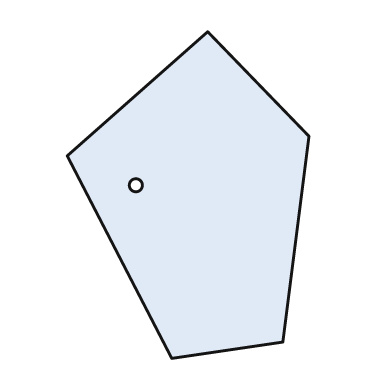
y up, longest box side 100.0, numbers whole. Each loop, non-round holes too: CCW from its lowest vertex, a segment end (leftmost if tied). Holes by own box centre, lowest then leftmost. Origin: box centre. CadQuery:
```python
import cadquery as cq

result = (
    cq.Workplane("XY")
    .moveTo(-5.0, -50.0)
    .lineTo(29.0, -45.0)
    .lineTo(37.0, 18.0)
    .lineTo(6.0, 50.0)
    .lineTo(-37.0, 12.0)
    .close()
    .moveTo(-16.0, 3.0)
    .circle(2.0)
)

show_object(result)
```